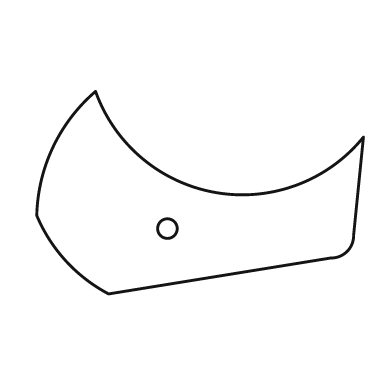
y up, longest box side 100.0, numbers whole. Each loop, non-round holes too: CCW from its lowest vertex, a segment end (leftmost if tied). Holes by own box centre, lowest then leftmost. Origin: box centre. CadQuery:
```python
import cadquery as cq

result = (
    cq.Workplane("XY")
    .moveTo(-28.0, -31.0)
    .lineTo(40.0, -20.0)
    .threePointArc((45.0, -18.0), (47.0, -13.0))
    .lineTo(50.0, 17.0)
    .threePointArc((5.0, 0.0), (-32.0, 31.0))
    .threePointArc((-45.0, 14.0), (-50.0, -7.0))
    .threePointArc((-41.0, -21.0), (-28.0, -31.0))
    .close()
    .moveTo(-10.0, -11.0)
    .circle(3.0)
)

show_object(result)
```